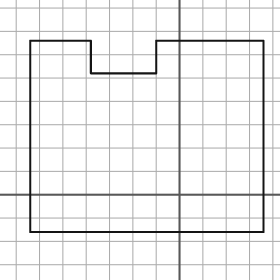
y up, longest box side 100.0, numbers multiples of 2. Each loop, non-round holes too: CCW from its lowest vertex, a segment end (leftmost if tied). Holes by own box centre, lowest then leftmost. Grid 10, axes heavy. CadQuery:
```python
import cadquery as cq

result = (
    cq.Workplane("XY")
    .moveTo(-64.0, -16.0)
    .lineTo(36.0, -16.0)
    .lineTo(36.0, 66.0)
    .lineTo(-10.0, 66.0)
    .lineTo(-10.0, 52.0)
    .lineTo(-38.0, 52.0)
    .lineTo(-38.0, 66.0)
    .lineTo(-64.0, 66.0)
    .close()
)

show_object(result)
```